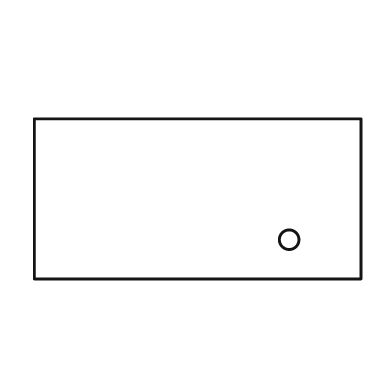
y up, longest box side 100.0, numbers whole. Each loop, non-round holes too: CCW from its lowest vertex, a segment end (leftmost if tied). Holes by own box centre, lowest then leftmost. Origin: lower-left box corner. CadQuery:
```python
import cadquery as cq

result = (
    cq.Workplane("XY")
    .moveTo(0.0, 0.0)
    .lineTo(100.0, 0.0)
    .lineTo(100.0, 49.0)
    .lineTo(0.0, 49.0)
    .close()
    .moveTo(78.0, 12.0)
    .circle(3.0)
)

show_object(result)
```